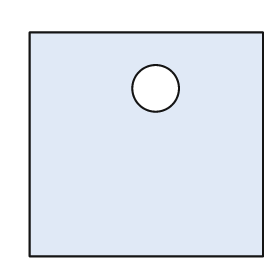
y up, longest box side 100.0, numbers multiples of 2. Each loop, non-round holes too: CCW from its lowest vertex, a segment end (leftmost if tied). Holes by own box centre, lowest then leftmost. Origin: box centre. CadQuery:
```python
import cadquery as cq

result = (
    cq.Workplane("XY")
    .moveTo(-50.0, -48.0)
    .lineTo(50.0, -48.0)
    .lineTo(50.0, 48.0)
    .lineTo(-50.0, 48.0)
    .close()
    .moveTo(4.0, 24.0)
    .circle(10.0)
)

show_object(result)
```